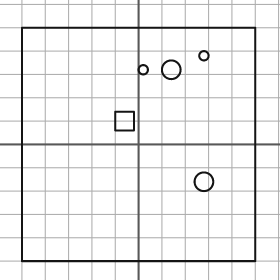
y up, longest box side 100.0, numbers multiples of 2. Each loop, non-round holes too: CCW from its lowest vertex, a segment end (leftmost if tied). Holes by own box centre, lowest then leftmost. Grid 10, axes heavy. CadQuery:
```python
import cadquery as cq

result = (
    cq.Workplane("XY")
    .moveTo(-50.0, -50.0)
    .lineTo(50.0, -50.0)
    .lineTo(50.0, 50.0)
    .lineTo(-50.0, 50.0)
    .close()
    .moveTo(28.0, -16.0)
    .circle(4.0)
    .moveTo(-10.0, 6.0)
    .lineTo(-2.0, 6.0)
    .lineTo(-2.0, 14.0)
    .lineTo(-10.0, 14.0)
    .close()
    .moveTo(2.0, 32.0)
    .circle(2.0)
    .moveTo(14.0, 32.0)
    .circle(4.0)
    .moveTo(28.0, 38.0)
    .circle(2.0)
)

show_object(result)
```